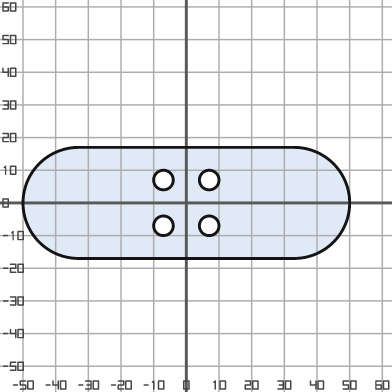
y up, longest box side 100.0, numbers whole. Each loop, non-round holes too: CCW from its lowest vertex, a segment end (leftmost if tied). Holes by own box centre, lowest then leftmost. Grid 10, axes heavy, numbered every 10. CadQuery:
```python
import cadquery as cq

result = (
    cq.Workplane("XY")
    .moveTo(-33.0, -17.0)
    .lineTo(33.0, -17.0)
    .threePointArc((50.0, 0.0), (33.0, 17.0))
    .lineTo(-33.0, 17.0)
    .threePointArc((-50.0, 0.0), (-33.0, -17.0))
    .close()
    .moveTo(-7.0, -7.0)
    .circle(3.0)
    .moveTo(7.0, -7.0)
    .circle(3.0)
    .moveTo(-7.0, 7.0)
    .circle(3.0)
    .moveTo(7.0, 7.0)
    .circle(3.0)
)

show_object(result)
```